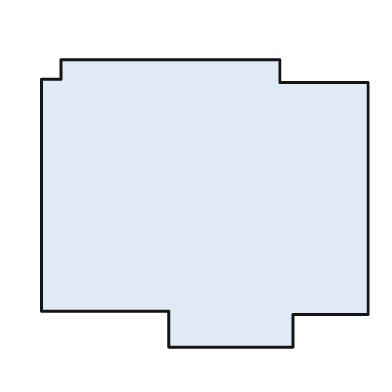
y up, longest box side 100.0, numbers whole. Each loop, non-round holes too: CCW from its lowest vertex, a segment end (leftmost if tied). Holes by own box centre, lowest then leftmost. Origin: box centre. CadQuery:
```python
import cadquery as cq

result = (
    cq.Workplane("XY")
    .moveTo(-11.0, -44.0)
    .lineTo(27.0, -44.0)
    .lineTo(27.0, -34.0)
    .lineTo(50.0, -34.0)
    .lineTo(50.0, 37.0)
    .lineTo(23.0, 37.0)
    .lineTo(23.0, 44.0)
    .lineTo(-44.0, 44.0)
    .lineTo(-44.0, 38.0)
    .lineTo(-50.0, 38.0)
    .lineTo(-50.0, -33.0)
    .lineTo(-11.0, -33.0)
    .close()
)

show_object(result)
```